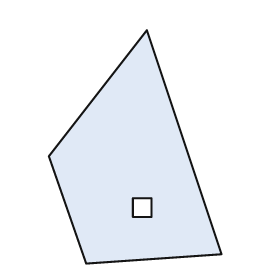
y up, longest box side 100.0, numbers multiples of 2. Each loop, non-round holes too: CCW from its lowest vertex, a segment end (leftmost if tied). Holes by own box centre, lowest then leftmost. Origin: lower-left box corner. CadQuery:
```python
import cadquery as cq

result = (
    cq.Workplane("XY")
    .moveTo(16.0, 0.0)
    .lineTo(74.0, 4.0)
    .lineTo(42.0, 100.0)
    .lineTo(0.0, 46.0)
    .close()
    .moveTo(36.0, 20.0)
    .lineTo(44.0, 20.0)
    .lineTo(44.0, 28.0)
    .lineTo(36.0, 28.0)
    .close()
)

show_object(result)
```